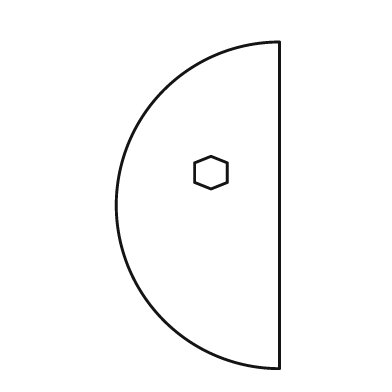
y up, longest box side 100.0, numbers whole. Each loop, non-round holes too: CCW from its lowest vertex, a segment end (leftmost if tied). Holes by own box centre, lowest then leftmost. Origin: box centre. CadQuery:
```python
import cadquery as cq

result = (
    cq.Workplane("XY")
    .moveTo(25.0, -50.0)
    .lineTo(25.0, 50.0)
    .threePointArc((-25.0, 0.0), (25.0, -50.0))
    .close()
    .moveTo(4.0, 5.0)
    .lineTo(9.0, 7.0)
    .lineTo(9.0, 13.0)
    .lineTo(4.0, 15.0)
    .lineTo(-1.0, 13.0)
    .lineTo(-1.0, 7.0)
    .close()
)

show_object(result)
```